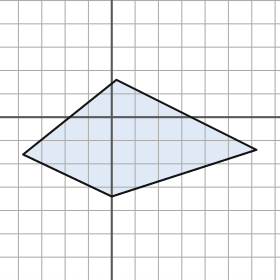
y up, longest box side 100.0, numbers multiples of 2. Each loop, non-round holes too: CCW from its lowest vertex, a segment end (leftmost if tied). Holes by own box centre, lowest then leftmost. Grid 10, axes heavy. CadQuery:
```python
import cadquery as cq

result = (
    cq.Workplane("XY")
    .moveTo(0.0, -34.0)
    .lineTo(62.0, -14.0)
    .lineTo(2.0, 16.0)
    .lineTo(-38.0, -16.0)
    .close()
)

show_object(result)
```